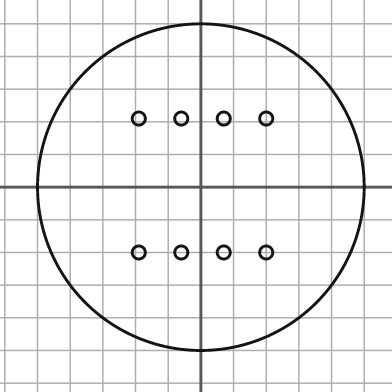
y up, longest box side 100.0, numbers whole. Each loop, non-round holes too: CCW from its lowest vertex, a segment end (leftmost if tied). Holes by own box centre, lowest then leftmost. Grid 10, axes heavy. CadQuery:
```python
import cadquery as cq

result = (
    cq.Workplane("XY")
    .moveTo(0.0, 0.0)
    .circle(50.0)
    .moveTo(-19.0, -20.0)
    .circle(2.0)
    .moveTo(-6.0, -20.0)
    .circle(2.0)
    .moveTo(7.0, -20.0)
    .circle(2.0)
    .moveTo(20.0, -20.0)
    .circle(2.0)
    .moveTo(-19.0, 21.0)
    .circle(2.0)
    .moveTo(-6.0, 21.0)
    .circle(2.0)
    .moveTo(7.0, 21.0)
    .circle(2.0)
    .moveTo(20.0, 21.0)
    .circle(2.0)
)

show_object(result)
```